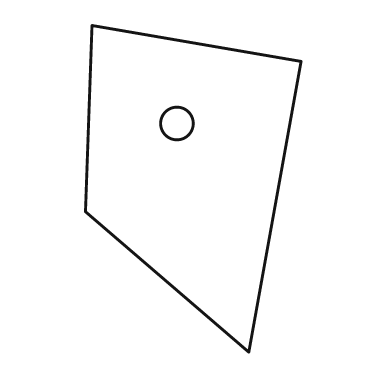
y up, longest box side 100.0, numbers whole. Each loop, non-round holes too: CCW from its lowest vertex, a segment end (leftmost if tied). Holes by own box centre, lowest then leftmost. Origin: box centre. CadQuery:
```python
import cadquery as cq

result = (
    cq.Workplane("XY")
    .moveTo(17.0, -50.0)
    .lineTo(33.0, 39.0)
    .lineTo(-31.0, 50.0)
    .lineTo(-33.0, -7.0)
    .close()
    .moveTo(-5.0, 20.0)
    .circle(5.0)
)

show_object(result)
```